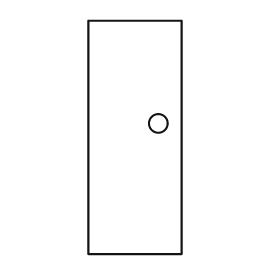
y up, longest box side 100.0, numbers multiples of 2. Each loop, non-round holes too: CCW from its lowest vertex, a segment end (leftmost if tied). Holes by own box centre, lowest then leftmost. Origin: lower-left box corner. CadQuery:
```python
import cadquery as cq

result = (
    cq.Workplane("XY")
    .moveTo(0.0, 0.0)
    .lineTo(40.0, 0.0)
    .lineTo(40.0, 100.0)
    .lineTo(0.0, 100.0)
    .close()
    .moveTo(30.0, 56.0)
    .circle(4.0)
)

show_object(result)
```